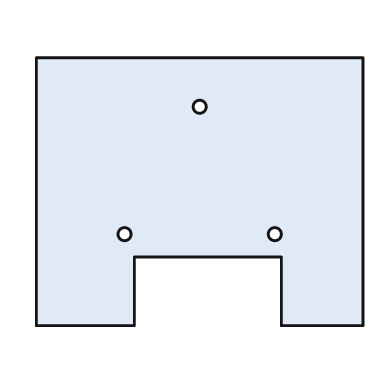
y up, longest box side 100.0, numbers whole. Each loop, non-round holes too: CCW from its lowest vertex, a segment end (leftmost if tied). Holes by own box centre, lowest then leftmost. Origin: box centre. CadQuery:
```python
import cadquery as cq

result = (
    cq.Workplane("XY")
    .moveTo(-50.0, -41.0)
    .lineTo(-20.0, -41.0)
    .lineTo(-20.0, -20.0)
    .lineTo(25.0, -20.0)
    .lineTo(25.0, -41.0)
    .lineTo(50.0, -41.0)
    .lineTo(50.0, 41.0)
    .lineTo(-50.0, 41.0)
    .close()
    .moveTo(-23.0, -13.0)
    .circle(2.0)
    .moveTo(23.0, -13.0)
    .circle(2.0)
    .moveTo(0.0, 26.0)
    .circle(2.0)
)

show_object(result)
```